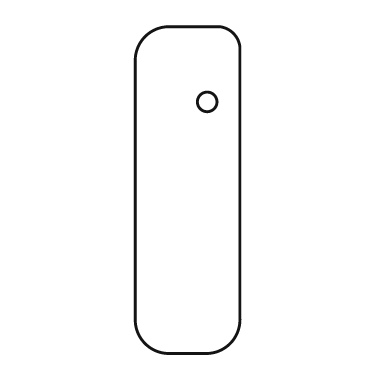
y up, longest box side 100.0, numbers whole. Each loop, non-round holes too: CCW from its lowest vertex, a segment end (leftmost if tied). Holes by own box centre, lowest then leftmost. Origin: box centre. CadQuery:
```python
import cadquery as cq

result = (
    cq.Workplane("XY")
    .moveTo(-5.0, -50.0)
    .lineTo(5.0, -50.0)
    .threePointArc((13.0, -47.0), (16.0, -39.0))
    .lineTo(16.0, 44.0)
    .threePointArc((14.0, 48.0), (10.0, 50.0))
    .lineTo(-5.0, 50.0)
    .threePointArc((-13.0, 47.0), (-16.0, 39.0))
    .lineTo(-16.0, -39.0)
    .threePointArc((-13.0, -47.0), (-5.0, -50.0))
    .close()
    .moveTo(6.0, 27.0)
    .circle(3.0)
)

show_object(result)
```